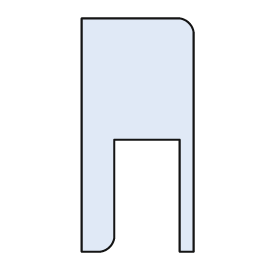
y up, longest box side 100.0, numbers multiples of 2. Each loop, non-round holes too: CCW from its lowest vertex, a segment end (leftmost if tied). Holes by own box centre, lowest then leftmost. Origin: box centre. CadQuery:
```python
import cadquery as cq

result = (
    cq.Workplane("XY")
    .moveTo(-24.0, -50.0)
    .lineTo(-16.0, -50.0)
    .threePointArc((-12.0, -48.0), (-10.0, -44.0))
    .lineTo(-10.0, -2.0)
    .lineTo(18.0, -2.0)
    .lineTo(18.0, -50.0)
    .lineTo(24.0, -50.0)
    .lineTo(24.0, 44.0)
    .threePointArc((22.0, 48.0), (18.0, 50.0))
    .lineTo(-24.0, 50.0)
    .close()
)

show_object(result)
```